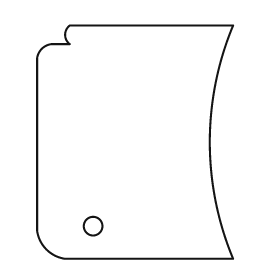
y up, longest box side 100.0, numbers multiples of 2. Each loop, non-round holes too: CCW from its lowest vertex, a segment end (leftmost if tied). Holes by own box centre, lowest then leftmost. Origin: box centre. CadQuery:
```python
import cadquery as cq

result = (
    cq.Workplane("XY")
    .moveTo(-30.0, -50.0)
    .lineTo(42.0, -50.0)
    .threePointArc((32.0, 0.0), (42.0, 50.0))
    .lineTo(-28.0, 50.0)
    .threePointArc((-30.0, 46.0), (-28.0, 42.0))
    .lineTo(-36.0, 42.0)
    .threePointArc((-40.0, 40.0), (-42.0, 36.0))
    .lineTo(-42.0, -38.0)
    .threePointArc((-38.0, -46.0), (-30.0, -50.0))
    .close()
    .moveTo(-18.0, -36.0)
    .circle(4.0)
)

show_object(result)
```